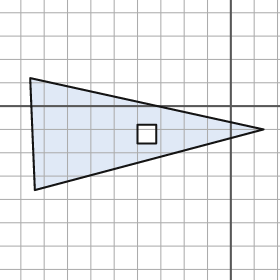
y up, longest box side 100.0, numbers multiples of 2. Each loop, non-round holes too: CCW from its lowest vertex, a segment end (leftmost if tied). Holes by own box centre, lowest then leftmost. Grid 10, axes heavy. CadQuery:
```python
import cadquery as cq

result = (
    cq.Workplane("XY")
    .moveTo(-84.0, -36.0)
    .lineTo(14.0, -10.0)
    .lineTo(-86.0, 12.0)
    .close()
    .moveTo(-40.0, -16.0)
    .lineTo(-32.0, -16.0)
    .lineTo(-32.0, -8.0)
    .lineTo(-40.0, -8.0)
    .close()
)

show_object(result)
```